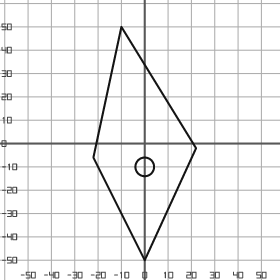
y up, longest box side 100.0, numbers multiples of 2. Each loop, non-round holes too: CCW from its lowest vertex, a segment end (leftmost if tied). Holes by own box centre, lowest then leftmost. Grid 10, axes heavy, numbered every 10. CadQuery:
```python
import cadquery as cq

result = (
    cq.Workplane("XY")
    .moveTo(0.0, -50.0)
    .lineTo(22.0, -2.0)
    .lineTo(-10.0, 50.0)
    .lineTo(-22.0, -6.0)
    .close()
    .moveTo(0.0, -10.0)
    .circle(4.0)
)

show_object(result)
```